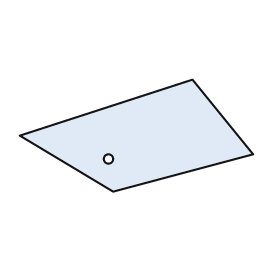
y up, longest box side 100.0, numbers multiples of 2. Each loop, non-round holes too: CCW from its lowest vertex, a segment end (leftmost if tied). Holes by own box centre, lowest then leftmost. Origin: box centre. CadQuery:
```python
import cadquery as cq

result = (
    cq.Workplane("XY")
    .moveTo(-10.0, -24.0)
    .lineTo(50.0, -8.0)
    .lineTo(24.0, 24.0)
    .lineTo(-50.0, 0.0)
    .close()
    .moveTo(-12.0, -10.0)
    .circle(2.0)
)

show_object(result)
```